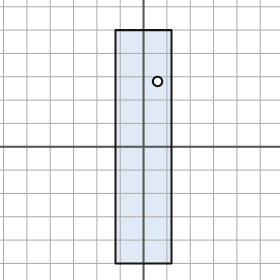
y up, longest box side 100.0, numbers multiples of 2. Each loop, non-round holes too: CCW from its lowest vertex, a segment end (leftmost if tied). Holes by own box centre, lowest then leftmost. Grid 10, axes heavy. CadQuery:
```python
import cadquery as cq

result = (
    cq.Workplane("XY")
    .moveTo(-12.0, -50.0)
    .lineTo(12.0, -50.0)
    .lineTo(12.0, 50.0)
    .lineTo(-12.0, 50.0)
    .close()
    .moveTo(6.0, 28.0)
    .circle(2.0)
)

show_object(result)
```